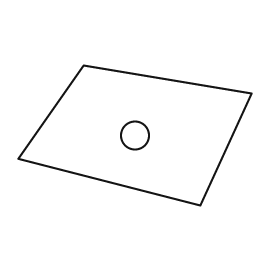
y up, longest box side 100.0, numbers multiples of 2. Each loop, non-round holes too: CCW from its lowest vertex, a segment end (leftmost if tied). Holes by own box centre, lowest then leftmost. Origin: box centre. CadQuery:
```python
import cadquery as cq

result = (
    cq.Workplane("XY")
    .moveTo(28.0, -30.0)
    .lineTo(50.0, 18.0)
    .lineTo(-22.0, 30.0)
    .lineTo(-50.0, -10.0)
    .close()
    .moveTo(0.0, 0.0)
    .circle(6.0)
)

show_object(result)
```